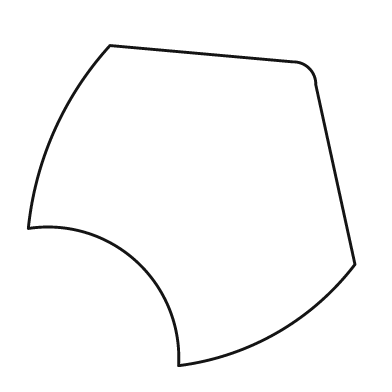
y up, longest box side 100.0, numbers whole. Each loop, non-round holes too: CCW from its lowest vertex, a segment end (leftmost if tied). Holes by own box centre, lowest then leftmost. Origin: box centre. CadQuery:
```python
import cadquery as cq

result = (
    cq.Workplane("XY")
    .moveTo(-4.0, -49.0)
    .threePointArc((26.0, -39.0), (50.0, -18.0))
    .lineTo(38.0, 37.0)
    .threePointArc((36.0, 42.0), (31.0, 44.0))
    .lineTo(-25.0, 49.0)
    .threePointArc((-42.0, 23.0), (-50.0, -7.0))
    .threePointArc((-17.0, -17.0), (-4.0, -49.0))
    .close()
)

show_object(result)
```